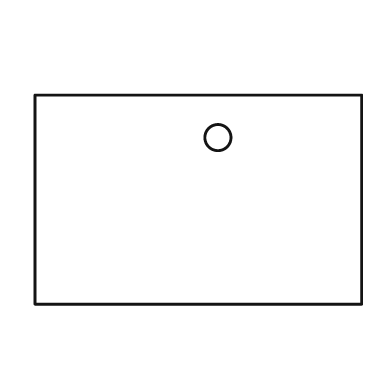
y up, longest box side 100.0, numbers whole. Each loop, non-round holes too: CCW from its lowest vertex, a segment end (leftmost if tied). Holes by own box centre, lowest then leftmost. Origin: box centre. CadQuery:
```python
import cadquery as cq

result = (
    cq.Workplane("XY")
    .moveTo(-50.0, -32.0)
    .lineTo(50.0, -32.0)
    .lineTo(50.0, 32.0)
    .lineTo(-50.0, 32.0)
    .close()
    .moveTo(6.0, 19.0)
    .circle(4.0)
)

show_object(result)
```